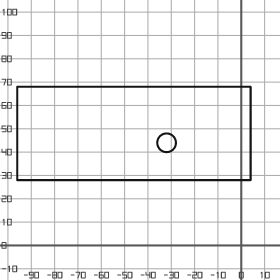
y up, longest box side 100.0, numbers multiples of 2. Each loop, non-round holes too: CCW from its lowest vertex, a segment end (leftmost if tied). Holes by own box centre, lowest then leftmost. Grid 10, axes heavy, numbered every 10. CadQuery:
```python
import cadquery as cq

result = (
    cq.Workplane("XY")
    .moveTo(-96.0, 28.0)
    .lineTo(4.0, 28.0)
    .lineTo(4.0, 68.0)
    .lineTo(-96.0, 68.0)
    .close()
    .moveTo(-32.0, 44.0)
    .circle(4.0)
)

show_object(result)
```